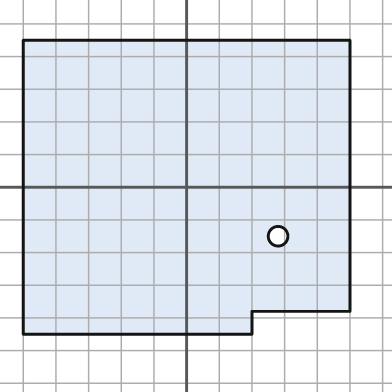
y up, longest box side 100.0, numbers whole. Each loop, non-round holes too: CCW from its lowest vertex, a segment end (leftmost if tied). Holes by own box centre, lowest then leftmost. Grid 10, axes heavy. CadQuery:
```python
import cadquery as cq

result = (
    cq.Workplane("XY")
    .moveTo(-50.0, -45.0)
    .lineTo(20.0, -45.0)
    .lineTo(20.0, -38.0)
    .lineTo(50.0, -38.0)
    .lineTo(50.0, 45.0)
    .lineTo(-50.0, 45.0)
    .close()
    .moveTo(28.0, -15.0)
    .circle(3.0)
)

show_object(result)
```